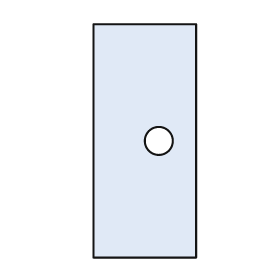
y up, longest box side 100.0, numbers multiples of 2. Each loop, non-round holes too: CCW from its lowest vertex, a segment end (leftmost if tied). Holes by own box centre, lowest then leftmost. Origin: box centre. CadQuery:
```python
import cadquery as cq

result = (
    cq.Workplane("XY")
    .moveTo(-22.0, -50.0)
    .lineTo(22.0, -50.0)
    .lineTo(22.0, 50.0)
    .lineTo(-22.0, 50.0)
    .close()
    .moveTo(6.0, 0.0)
    .circle(6.0)
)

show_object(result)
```